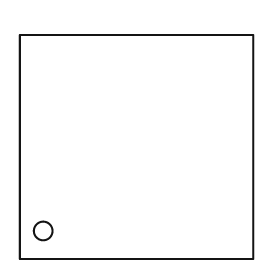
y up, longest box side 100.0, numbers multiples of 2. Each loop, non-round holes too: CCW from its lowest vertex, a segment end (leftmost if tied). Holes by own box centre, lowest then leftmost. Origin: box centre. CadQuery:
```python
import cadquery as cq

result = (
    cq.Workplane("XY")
    .moveTo(-50.0, -48.0)
    .lineTo(50.0, -48.0)
    .lineTo(50.0, 48.0)
    .lineTo(-50.0, 48.0)
    .close()
    .moveTo(-40.0, -36.0)
    .circle(4.0)
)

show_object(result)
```